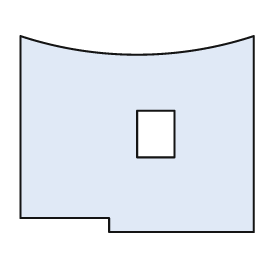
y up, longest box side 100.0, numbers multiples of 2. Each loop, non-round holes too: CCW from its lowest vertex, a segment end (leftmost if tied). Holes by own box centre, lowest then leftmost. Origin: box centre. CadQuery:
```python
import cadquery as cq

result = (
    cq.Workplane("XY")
    .moveTo(-12.0, -42.0)
    .lineTo(50.0, -42.0)
    .lineTo(50.0, 42.0)
    .threePointArc((0.0, 34.0), (-50.0, 42.0))
    .lineTo(-50.0, -36.0)
    .lineTo(-12.0, -36.0)
    .close()
    .moveTo(0.0, -10.0)
    .lineTo(16.0, -10.0)
    .lineTo(16.0, 10.0)
    .lineTo(0.0, 10.0)
    .close()
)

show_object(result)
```